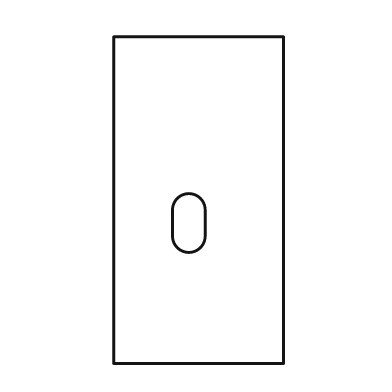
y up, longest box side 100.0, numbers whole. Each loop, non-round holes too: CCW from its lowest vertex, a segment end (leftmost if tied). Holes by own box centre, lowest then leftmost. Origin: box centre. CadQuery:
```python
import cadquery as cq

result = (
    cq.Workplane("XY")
    .moveTo(-26.0, -50.0)
    .lineTo(26.0, -50.0)
    .lineTo(26.0, 50.0)
    .lineTo(-26.0, 50.0)
    .close()
    .moveTo(-8.0, -11.0)
    .threePointArc((-3.0, -16.0), (2.0, -11.0))
    .lineTo(2.0, -3.0)
    .threePointArc((-3.0, 2.0), (-8.0, -3.0))
    .close()
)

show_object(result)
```